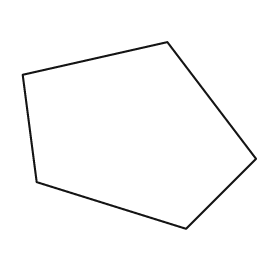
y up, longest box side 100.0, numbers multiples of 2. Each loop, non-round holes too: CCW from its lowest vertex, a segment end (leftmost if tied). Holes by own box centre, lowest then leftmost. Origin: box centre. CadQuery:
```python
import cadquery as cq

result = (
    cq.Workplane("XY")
    .moveTo(20.0, -40.0)
    .lineTo(50.0, -10.0)
    .lineTo(12.0, 40.0)
    .lineTo(-50.0, 26.0)
    .lineTo(-44.0, -20.0)
    .close()
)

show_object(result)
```